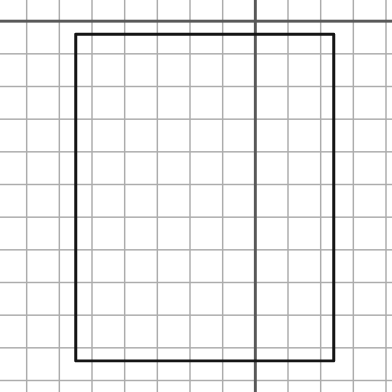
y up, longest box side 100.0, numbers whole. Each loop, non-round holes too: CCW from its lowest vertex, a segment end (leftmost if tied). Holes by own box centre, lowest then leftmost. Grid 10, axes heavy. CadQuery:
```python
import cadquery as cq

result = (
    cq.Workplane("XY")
    .moveTo(-55.0, -104.0)
    .lineTo(24.0, -104.0)
    .lineTo(24.0, -4.0)
    .lineTo(-55.0, -4.0)
    .close()
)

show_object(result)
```